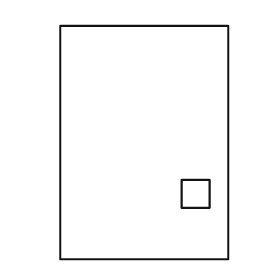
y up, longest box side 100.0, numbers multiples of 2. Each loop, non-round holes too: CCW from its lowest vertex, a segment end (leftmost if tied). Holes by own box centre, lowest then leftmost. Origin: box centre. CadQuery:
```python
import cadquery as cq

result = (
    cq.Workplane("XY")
    .moveTo(-36.0, -50.0)
    .lineTo(36.0, -50.0)
    .lineTo(36.0, 50.0)
    .lineTo(-36.0, 50.0)
    .close()
    .moveTo(16.0, -28.0)
    .lineTo(28.0, -28.0)
    .lineTo(28.0, -16.0)
    .lineTo(16.0, -16.0)
    .close()
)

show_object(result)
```